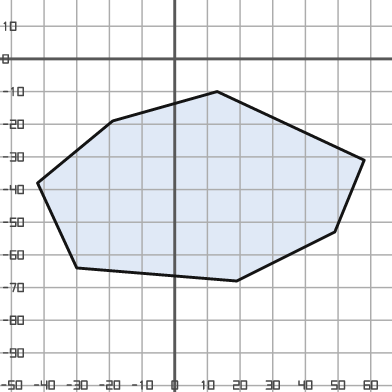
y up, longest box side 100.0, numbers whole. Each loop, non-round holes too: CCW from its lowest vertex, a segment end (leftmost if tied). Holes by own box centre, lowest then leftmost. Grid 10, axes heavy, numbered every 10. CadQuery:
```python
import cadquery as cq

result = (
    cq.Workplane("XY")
    .moveTo(19.0, -68.0)
    .lineTo(49.0, -53.0)
    .lineTo(58.0, -31.0)
    .lineTo(13.0, -10.0)
    .lineTo(-19.0, -19.0)
    .lineTo(-42.0, -38.0)
    .lineTo(-30.0, -64.0)
    .close()
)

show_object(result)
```